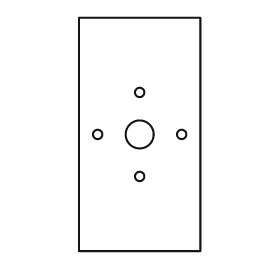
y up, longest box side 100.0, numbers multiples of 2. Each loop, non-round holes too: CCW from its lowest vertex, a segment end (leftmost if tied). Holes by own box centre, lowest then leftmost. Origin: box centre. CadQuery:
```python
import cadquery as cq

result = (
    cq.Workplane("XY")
    .moveTo(-26.0, -50.0)
    .lineTo(26.0, -50.0)
    .lineTo(26.0, 50.0)
    .lineTo(-26.0, 50.0)
    .close()
    .moveTo(0.0, -18.0)
    .circle(2.0)
    .moveTo(-18.0, 0.0)
    .circle(2.0)
    .moveTo(0.0, 0.0)
    .circle(6.0)
    .moveTo(18.0, 0.0)
    .circle(2.0)
    .moveTo(0.0, 18.0)
    .circle(2.0)
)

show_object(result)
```